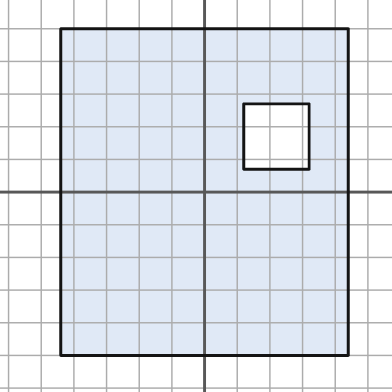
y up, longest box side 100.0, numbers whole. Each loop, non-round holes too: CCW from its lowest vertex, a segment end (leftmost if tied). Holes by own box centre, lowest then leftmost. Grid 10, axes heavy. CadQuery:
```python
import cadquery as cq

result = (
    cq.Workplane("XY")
    .moveTo(-44.0, -50.0)
    .lineTo(44.0, -50.0)
    .lineTo(44.0, 50.0)
    .lineTo(-44.0, 50.0)
    .close()
    .moveTo(12.0, 7.0)
    .lineTo(32.0, 7.0)
    .lineTo(32.0, 27.0)
    .lineTo(12.0, 27.0)
    .close()
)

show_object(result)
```